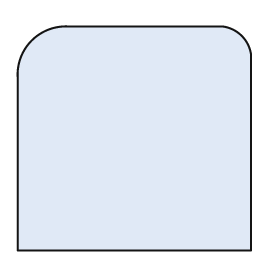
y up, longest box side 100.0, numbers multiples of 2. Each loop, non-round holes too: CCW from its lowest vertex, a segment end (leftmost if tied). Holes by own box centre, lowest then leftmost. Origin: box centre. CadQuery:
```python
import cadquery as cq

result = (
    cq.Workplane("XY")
    .moveTo(-50.0, -48.0)
    .lineTo(50.0, -48.0)
    .lineTo(50.0, 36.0)
    .threePointArc((46.0, 44.0), (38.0, 48.0))
    .lineTo(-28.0, 48.0)
    .threePointArc((-44.0, 42.0), (-50.0, 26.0))
    .close()
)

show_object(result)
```